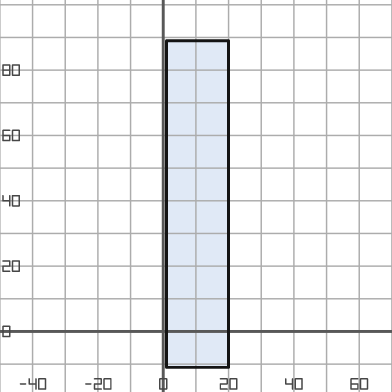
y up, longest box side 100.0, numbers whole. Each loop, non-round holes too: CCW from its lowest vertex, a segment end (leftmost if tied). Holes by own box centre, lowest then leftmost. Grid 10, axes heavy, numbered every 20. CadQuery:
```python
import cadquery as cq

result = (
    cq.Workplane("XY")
    .moveTo(1.0, -11.0)
    .lineTo(20.0, -11.0)
    .lineTo(20.0, 89.0)
    .lineTo(1.0, 89.0)
    .close()
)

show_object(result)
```